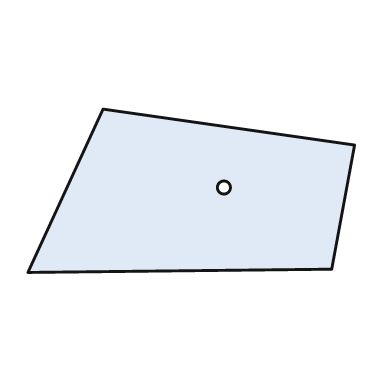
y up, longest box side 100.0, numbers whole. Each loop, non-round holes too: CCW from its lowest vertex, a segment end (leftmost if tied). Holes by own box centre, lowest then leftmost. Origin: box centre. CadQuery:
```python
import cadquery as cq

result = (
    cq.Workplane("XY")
    .moveTo(-50.0, -25.0)
    .lineTo(43.0, -24.0)
    .lineTo(50.0, 14.0)
    .lineTo(-27.0, 25.0)
    .close()
    .moveTo(10.0, 1.0)
    .circle(2.0)
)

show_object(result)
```